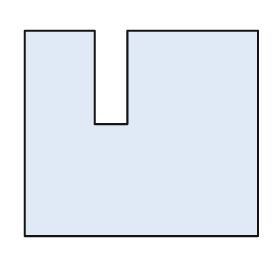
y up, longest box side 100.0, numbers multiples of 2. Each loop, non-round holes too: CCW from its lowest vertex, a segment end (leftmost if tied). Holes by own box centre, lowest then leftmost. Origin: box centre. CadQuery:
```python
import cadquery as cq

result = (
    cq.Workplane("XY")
    .moveTo(-50.0, -44.0)
    .lineTo(50.0, -44.0)
    .lineTo(50.0, 44.0)
    .lineTo(-6.0, 44.0)
    .lineTo(-6.0, 4.0)
    .lineTo(-20.0, 4.0)
    .lineTo(-20.0, 44.0)
    .lineTo(-50.0, 44.0)
    .close()
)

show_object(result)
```